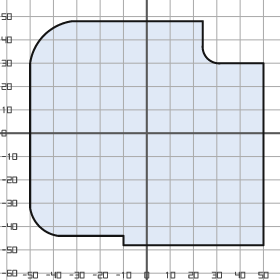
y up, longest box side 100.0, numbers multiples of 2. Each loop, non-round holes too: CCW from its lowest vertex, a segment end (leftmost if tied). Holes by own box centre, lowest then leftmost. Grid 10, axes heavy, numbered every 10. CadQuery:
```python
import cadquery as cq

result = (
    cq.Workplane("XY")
    .moveTo(-10.0, -48.0)
    .lineTo(50.0, -48.0)
    .lineTo(50.0, 30.0)
    .lineTo(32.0, 30.0)
    .threePointArc((26.0, 32.0), (24.0, 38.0))
    .lineTo(24.0, 48.0)
    .lineTo(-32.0, 48.0)
    .threePointArc((-44.0, 42.0), (-50.0, 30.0))
    .lineTo(-50.0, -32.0)
    .threePointArc((-46.0, -40.0), (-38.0, -44.0))
    .lineTo(-10.0, -44.0)
    .close()
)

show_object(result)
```